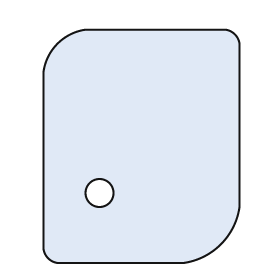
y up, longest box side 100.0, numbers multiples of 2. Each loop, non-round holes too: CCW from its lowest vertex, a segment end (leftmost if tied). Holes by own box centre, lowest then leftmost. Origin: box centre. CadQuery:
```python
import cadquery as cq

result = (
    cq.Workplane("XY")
    .moveTo(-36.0, -50.0)
    .lineTo(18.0, -50.0)
    .threePointArc((34.0, -42.0), (42.0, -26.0))
    .lineTo(42.0, 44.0)
    .threePointArc((40.0, 48.0), (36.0, 50.0))
    .lineTo(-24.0, 50.0)
    .threePointArc((-36.0, 44.0), (-42.0, 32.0))
    .lineTo(-42.0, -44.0)
    .threePointArc((-40.0, -48.0), (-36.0, -50.0))
    .close()
    .moveTo(-18.0, -20.0)
    .circle(6.0)
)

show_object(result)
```